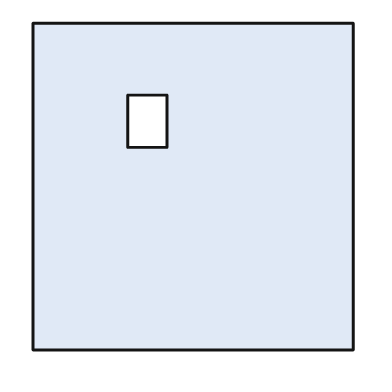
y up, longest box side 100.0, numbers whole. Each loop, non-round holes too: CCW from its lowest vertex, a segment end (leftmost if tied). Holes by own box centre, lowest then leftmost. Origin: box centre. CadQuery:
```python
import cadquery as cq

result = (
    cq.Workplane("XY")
    .moveTo(-49.0, -50.0)
    .lineTo(49.0, -50.0)
    .lineTo(49.0, 50.0)
    .lineTo(-49.0, 50.0)
    .close()
    .moveTo(-20.0, 12.0)
    .lineTo(-8.0, 12.0)
    .lineTo(-8.0, 28.0)
    .lineTo(-20.0, 28.0)
    .close()
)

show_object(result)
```